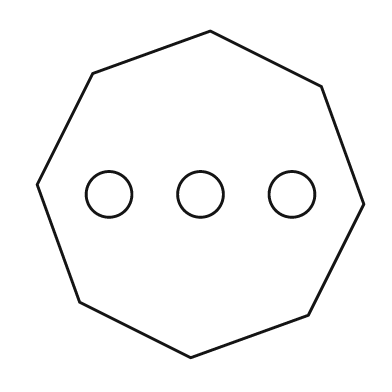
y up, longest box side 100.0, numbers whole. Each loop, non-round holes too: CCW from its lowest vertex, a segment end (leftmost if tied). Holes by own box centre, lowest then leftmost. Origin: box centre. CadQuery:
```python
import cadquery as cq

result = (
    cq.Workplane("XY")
    .moveTo(-3.0, -50.0)
    .lineTo(33.0, -37.0)
    .lineTo(50.0, -3.0)
    .lineTo(37.0, 33.0)
    .lineTo(3.0, 50.0)
    .lineTo(-33.0, 37.0)
    .lineTo(-50.0, 3.0)
    .lineTo(-37.0, -33.0)
    .close()
    .moveTo(-28.0, 0.0)
    .circle(7.0)
    .moveTo(0.0, 0.0)
    .circle(7.0)
    .moveTo(28.0, 0.0)
    .circle(7.0)
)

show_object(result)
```